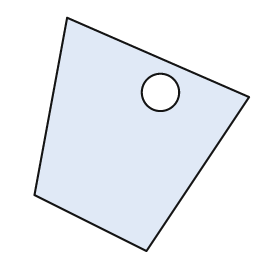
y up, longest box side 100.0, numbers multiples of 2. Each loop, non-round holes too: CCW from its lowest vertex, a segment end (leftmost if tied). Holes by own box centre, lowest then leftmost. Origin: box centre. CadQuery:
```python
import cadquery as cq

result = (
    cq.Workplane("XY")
    .moveTo(2.0, -50.0)
    .lineTo(46.0, 16.0)
    .lineTo(-32.0, 50.0)
    .lineTo(-46.0, -26.0)
    .close()
    .moveTo(8.0, 18.0)
    .circle(8.0)
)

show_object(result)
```